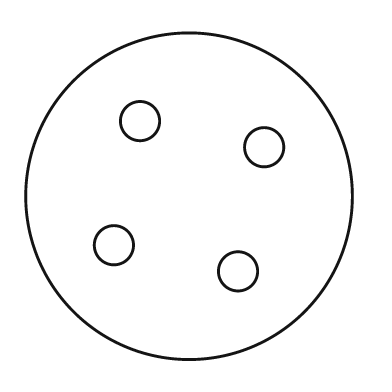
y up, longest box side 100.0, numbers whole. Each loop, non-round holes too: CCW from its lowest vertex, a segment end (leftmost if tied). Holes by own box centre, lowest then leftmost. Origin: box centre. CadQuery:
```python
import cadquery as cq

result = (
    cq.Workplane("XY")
    .moveTo(0.0, 0.0)
    .circle(50.0)
    .moveTo(15.0, -23.0)
    .circle(6.0)
    .moveTo(-23.0, -15.0)
    .circle(6.0)
    .moveTo(23.0, 15.0)
    .circle(6.0)
    .moveTo(-15.0, 23.0)
    .circle(6.0)
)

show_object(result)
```